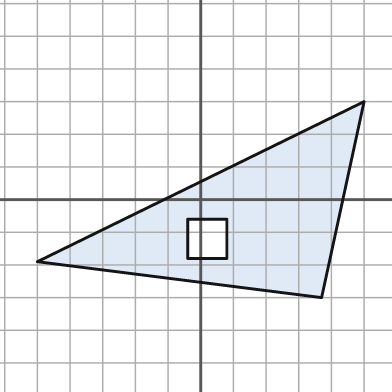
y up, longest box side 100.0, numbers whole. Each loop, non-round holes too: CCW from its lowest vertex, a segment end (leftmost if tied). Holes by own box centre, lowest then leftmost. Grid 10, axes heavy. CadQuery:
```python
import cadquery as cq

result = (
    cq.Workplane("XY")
    .moveTo(37.0, -30.0)
    .lineTo(50.0, 30.0)
    .lineTo(-50.0, -19.0)
    .close()
    .moveTo(-4.0, -18.0)
    .lineTo(8.0, -18.0)
    .lineTo(8.0, -6.0)
    .lineTo(-4.0, -6.0)
    .close()
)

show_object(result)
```